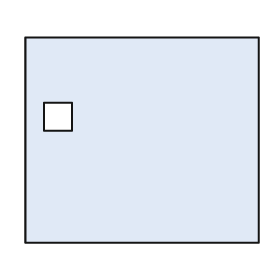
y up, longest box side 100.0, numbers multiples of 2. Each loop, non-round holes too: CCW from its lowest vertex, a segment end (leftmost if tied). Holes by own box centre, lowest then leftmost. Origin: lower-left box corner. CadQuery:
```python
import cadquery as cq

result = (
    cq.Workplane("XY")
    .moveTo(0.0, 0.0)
    .lineTo(100.0, 0.0)
    .lineTo(100.0, 88.0)
    .lineTo(0.0, 88.0)
    .close()
    .moveTo(8.0, 48.0)
    .lineTo(20.0, 48.0)
    .lineTo(20.0, 60.0)
    .lineTo(8.0, 60.0)
    .close()
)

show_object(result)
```